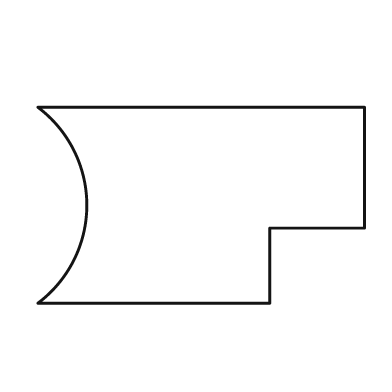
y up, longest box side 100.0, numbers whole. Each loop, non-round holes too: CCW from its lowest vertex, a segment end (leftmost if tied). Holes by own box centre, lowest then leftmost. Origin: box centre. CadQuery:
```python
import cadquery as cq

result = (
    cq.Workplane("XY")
    .moveTo(-50.0, -30.0)
    .lineTo(21.0, -30.0)
    .lineTo(21.0, -7.0)
    .lineTo(50.0, -7.0)
    .lineTo(50.0, 30.0)
    .lineTo(-50.0, 30.0)
    .threePointArc((-35.0, 0.0), (-50.0, -30.0))
    .close()
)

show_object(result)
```